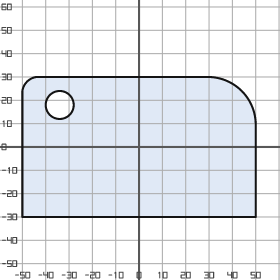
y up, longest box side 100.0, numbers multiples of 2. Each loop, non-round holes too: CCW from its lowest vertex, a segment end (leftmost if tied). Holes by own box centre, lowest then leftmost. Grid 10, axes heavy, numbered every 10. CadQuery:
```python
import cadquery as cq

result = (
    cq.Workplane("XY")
    .moveTo(-50.0, -30.0)
    .lineTo(50.0, -30.0)
    .lineTo(50.0, 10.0)
    .threePointArc((44.0, 24.0), (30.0, 30.0))
    .lineTo(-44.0, 30.0)
    .threePointArc((-48.0, 28.0), (-50.0, 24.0))
    .close()
    .moveTo(-34.0, 18.0)
    .circle(6.0)
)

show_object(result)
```